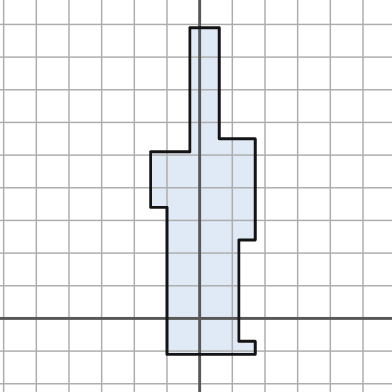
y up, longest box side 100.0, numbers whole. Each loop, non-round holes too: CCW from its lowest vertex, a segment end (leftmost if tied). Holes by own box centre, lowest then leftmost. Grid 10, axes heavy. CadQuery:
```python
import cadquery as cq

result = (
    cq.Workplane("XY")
    .moveTo(-10.0, -11.0)
    .lineTo(17.0, -11.0)
    .lineTo(17.0, -7.0)
    .lineTo(12.0, -7.0)
    .lineTo(12.0, 24.0)
    .lineTo(17.0, 24.0)
    .lineTo(17.0, 55.0)
    .lineTo(6.0, 55.0)
    .lineTo(6.0, 89.0)
    .lineTo(-3.0, 89.0)
    .lineTo(-3.0, 51.0)
    .lineTo(-15.0, 51.0)
    .lineTo(-15.0, 34.0)
    .lineTo(-10.0, 34.0)
    .close()
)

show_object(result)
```